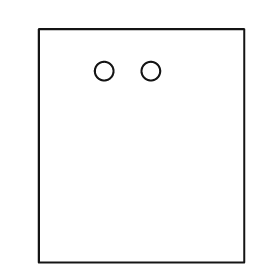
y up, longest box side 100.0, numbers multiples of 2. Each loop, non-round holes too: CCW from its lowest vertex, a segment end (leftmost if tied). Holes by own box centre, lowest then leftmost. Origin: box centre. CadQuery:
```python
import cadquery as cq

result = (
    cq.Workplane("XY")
    .moveTo(-44.0, -50.0)
    .lineTo(44.0, -50.0)
    .lineTo(44.0, 50.0)
    .lineTo(-44.0, 50.0)
    .close()
    .moveTo(-16.0, 32.0)
    .circle(4.0)
    .moveTo(4.0, 32.0)
    .circle(4.0)
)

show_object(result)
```